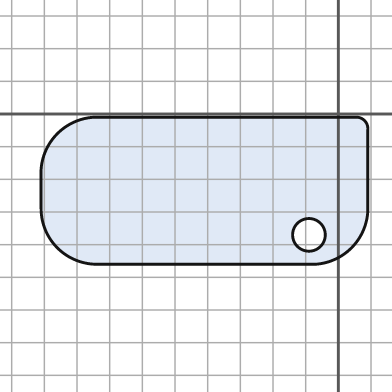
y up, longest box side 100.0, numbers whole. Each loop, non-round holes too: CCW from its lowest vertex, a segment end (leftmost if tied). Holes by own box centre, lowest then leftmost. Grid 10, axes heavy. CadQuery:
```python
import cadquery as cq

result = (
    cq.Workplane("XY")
    .moveTo(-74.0, -46.0)
    .lineTo(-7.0, -46.0)
    .threePointArc((4.0, -41.0), (9.0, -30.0))
    .lineTo(9.0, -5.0)
    .threePointArc((8.0, -2.0), (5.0, -1.0))
    .lineTo(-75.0, -1.0)
    .threePointArc((-86.0, -6.0), (-91.0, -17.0))
    .lineTo(-91.0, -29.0)
    .threePointArc((-86.0, -41.0), (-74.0, -46.0))
    .close()
    .moveTo(-9.0, -37.0)
    .circle(5.0)
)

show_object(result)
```